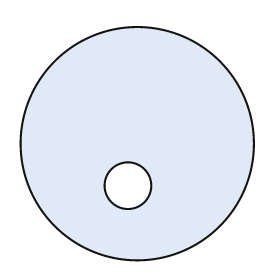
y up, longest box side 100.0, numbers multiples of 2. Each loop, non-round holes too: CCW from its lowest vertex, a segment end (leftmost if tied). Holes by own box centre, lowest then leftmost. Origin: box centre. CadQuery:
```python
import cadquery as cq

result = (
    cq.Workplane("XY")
    .moveTo(0.0, 0.0)
    .circle(50.0)
    .moveTo(-4.0, -18.0)
    .circle(10.0)
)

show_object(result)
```